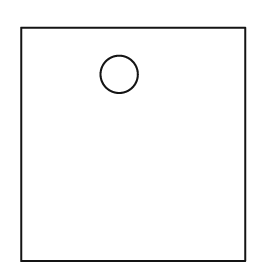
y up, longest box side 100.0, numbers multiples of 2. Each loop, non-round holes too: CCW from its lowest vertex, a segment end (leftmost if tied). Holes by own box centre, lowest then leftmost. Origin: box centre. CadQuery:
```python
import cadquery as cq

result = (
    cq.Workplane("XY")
    .moveTo(-48.0, -50.0)
    .lineTo(48.0, -50.0)
    .lineTo(48.0, 50.0)
    .lineTo(-48.0, 50.0)
    .close()
    .moveTo(-6.0, 30.0)
    .circle(8.0)
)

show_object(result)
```